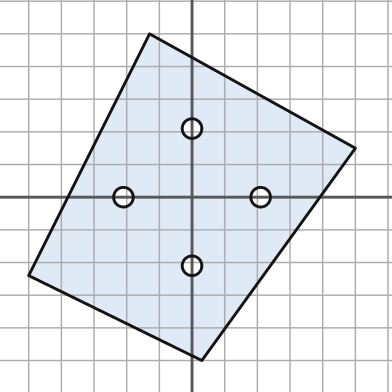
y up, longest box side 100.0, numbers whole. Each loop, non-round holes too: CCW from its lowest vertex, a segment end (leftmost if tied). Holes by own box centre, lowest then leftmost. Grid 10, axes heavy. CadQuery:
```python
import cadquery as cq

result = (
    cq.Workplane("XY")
    .moveTo(3.0, -50.0)
    .lineTo(50.0, 15.0)
    .lineTo(-13.0, 50.0)
    .lineTo(-50.0, -24.0)
    .close()
    .moveTo(0.0, -21.0)
    .circle(3.0)
    .moveTo(-21.0, 0.0)
    .circle(3.0)
    .moveTo(21.0, 0.0)
    .circle(3.0)
    .moveTo(0.0, 21.0)
    .circle(3.0)
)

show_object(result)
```